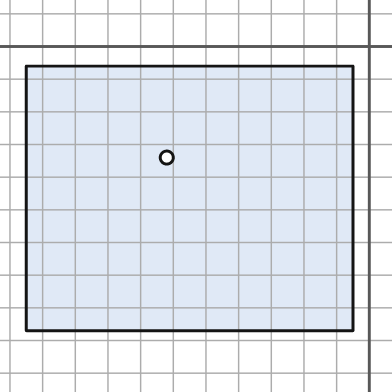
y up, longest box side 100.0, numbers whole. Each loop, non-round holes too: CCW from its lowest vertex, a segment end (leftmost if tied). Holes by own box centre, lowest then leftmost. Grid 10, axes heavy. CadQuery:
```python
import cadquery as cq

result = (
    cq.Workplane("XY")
    .moveTo(-105.0, -87.0)
    .lineTo(-5.0, -87.0)
    .lineTo(-5.0, -6.0)
    .lineTo(-105.0, -6.0)
    .close()
    .moveTo(-62.0, -34.0)
    .circle(2.0)
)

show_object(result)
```